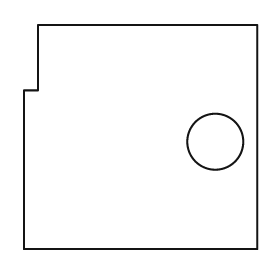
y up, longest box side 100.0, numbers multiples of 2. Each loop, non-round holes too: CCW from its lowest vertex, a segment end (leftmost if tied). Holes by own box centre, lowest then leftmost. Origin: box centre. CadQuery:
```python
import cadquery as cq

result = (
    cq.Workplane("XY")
    .moveTo(-50.0, -48.0)
    .lineTo(50.0, -48.0)
    .lineTo(50.0, 48.0)
    .lineTo(-44.0, 48.0)
    .lineTo(-44.0, 20.0)
    .lineTo(-50.0, 20.0)
    .close()
    .moveTo(32.0, -2.0)
    .circle(12.0)
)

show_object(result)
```